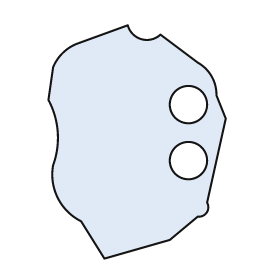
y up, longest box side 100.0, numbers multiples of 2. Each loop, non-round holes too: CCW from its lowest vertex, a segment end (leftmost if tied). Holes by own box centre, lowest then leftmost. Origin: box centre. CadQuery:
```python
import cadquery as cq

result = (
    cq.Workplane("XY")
    .moveTo(-14.0, -50.0)
    .lineTo(14.0, -42.0)
    .lineTo(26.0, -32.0)
    .threePointArc((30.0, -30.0), (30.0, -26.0))
    .lineTo(38.0, 10.0)
    .lineTo(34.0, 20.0)
    .threePointArc((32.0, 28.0), (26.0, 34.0))
    .lineTo(10.0, 46.0)
    .threePointArc((2.0, 44.0), (-4.0, 50.0))
    .lineTo(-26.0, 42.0)
    .threePointArc((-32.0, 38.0), (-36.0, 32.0))
    .lineTo(-38.0, 18.0)
    .threePointArc((-34.0, 4.0), (-36.0, -10.0))
    .threePointArc((-34.0, -24.0), (-24.0, -34.0))
    .close()
    .moveTo(22.0, -8.0)
    .circle(8.0)
    .moveTo(22.0, 16.0)
    .circle(8.0)
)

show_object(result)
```